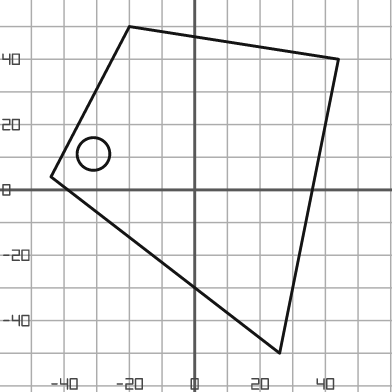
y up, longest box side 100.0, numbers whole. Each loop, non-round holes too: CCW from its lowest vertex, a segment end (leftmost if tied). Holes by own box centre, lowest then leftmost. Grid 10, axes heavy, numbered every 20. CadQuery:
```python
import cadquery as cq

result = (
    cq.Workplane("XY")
    .moveTo(26.0, -50.0)
    .lineTo(44.0, 40.0)
    .lineTo(-20.0, 50.0)
    .lineTo(-44.0, 4.0)
    .close()
    .moveTo(-31.0, 11.0)
    .circle(5.0)
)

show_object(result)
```